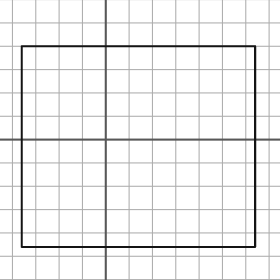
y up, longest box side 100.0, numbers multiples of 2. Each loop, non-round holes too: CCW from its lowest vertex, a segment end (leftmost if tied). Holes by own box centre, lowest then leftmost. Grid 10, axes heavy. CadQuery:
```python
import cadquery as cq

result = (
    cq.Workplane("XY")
    .moveTo(-36.0, -46.0)
    .lineTo(64.0, -46.0)
    .lineTo(64.0, 40.0)
    .lineTo(-36.0, 40.0)
    .close()
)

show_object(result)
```